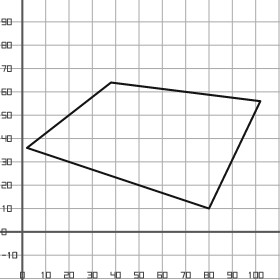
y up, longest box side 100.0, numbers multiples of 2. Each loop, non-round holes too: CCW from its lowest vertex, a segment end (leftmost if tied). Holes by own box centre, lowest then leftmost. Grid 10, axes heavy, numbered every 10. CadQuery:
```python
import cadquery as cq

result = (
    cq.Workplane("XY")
    .moveTo(80.0, 10.0)
    .lineTo(102.0, 56.0)
    .lineTo(38.0, 64.0)
    .lineTo(2.0, 36.0)
    .close()
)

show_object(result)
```